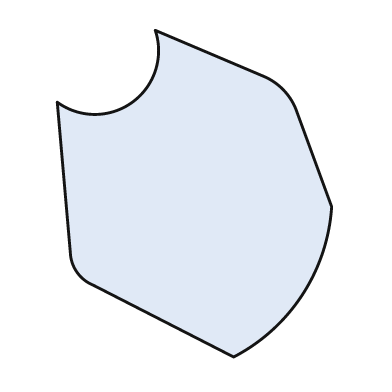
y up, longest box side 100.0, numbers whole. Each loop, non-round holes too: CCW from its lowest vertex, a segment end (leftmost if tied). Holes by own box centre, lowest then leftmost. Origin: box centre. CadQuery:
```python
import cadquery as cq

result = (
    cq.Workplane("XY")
    .moveTo(12.0, -50.0)
    .threePointArc((33.0, -31.0), (42.0, -4.0))
    .lineTo(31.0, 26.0)
    .threePointArc((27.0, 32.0), (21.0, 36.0))
    .lineTo(-12.0, 50.0)
    .threePointArc((-19.0, 28.0), (-42.0, 28.0))
    .lineTo(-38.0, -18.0)
    .threePointArc((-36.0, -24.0), (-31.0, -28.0))
    .close()
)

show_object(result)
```